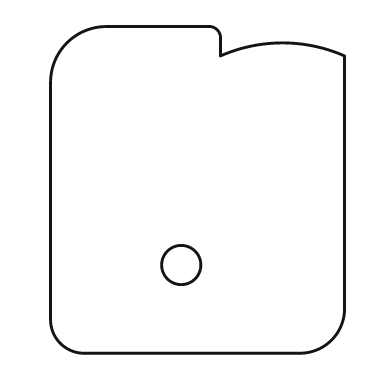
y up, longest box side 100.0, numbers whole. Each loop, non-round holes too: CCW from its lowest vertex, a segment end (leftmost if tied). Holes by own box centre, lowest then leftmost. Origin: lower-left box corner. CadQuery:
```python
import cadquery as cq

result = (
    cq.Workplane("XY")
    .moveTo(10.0, 0.0)
    .lineTo(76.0, 0.0)
    .threePointArc((86.0, 4.0), (90.0, 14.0))
    .lineTo(90.0, 91.0)
    .threePointArc((71.0, 95.0), (52.0, 91.0))
    .lineTo(52.0, 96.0)
    .threePointArc((51.0, 99.0), (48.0, 100.0))
    .lineTo(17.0, 100.0)
    .threePointArc((5.0, 95.0), (0.0, 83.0))
    .lineTo(0.0, 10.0)
    .threePointArc((3.0, 3.0), (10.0, 0.0))
    .close()
    .moveTo(40.0, 27.0)
    .circle(6.0)
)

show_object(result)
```